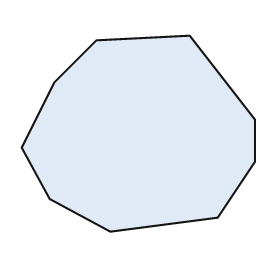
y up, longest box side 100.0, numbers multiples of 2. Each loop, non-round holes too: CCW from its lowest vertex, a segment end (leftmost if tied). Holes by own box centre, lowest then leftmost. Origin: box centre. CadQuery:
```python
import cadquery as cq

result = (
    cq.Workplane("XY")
    .moveTo(-12.0, -42.0)
    .lineTo(34.0, -36.0)
    .lineTo(50.0, -12.0)
    .lineTo(50.0, 6.0)
    .lineTo(22.0, 42.0)
    .lineTo(-18.0, 40.0)
    .lineTo(-36.0, 22.0)
    .lineTo(-50.0, -6.0)
    .lineTo(-38.0, -28.0)
    .close()
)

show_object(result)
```